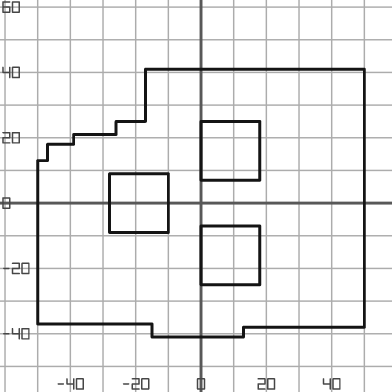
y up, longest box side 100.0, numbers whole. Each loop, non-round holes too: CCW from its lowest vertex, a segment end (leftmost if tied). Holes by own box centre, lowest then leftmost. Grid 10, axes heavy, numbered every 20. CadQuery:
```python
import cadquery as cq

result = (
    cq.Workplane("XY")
    .moveTo(-15.0, -41.0)
    .lineTo(13.0, -41.0)
    .lineTo(13.0, -38.0)
    .lineTo(50.0, -38.0)
    .lineTo(50.0, 41.0)
    .lineTo(-17.0, 41.0)
    .lineTo(-17.0, 25.0)
    .lineTo(-26.0, 25.0)
    .lineTo(-26.0, 21.0)
    .lineTo(-39.0, 21.0)
    .lineTo(-39.0, 18.0)
    .lineTo(-47.0, 18.0)
    .lineTo(-47.0, 13.0)
    .lineTo(-50.0, 13.0)
    .lineTo(-50.0, -37.0)
    .lineTo(-15.0, -37.0)
    .close()
    .moveTo(0.0, -25.0)
    .lineTo(18.0, -25.0)
    .lineTo(18.0, -7.0)
    .lineTo(0.0, -7.0)
    .close()
    .moveTo(-28.0, -9.0)
    .lineTo(-10.0, -9.0)
    .lineTo(-10.0, 9.0)
    .lineTo(-28.0, 9.0)
    .close()
    .moveTo(0.0, 7.0)
    .lineTo(18.0, 7.0)
    .lineTo(18.0, 25.0)
    .lineTo(0.0, 25.0)
    .close()
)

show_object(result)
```